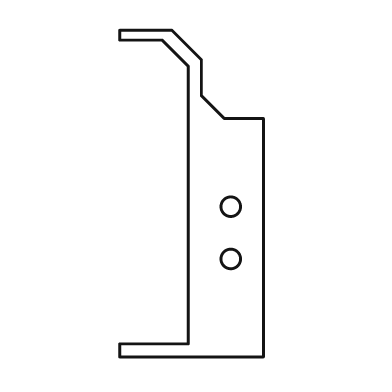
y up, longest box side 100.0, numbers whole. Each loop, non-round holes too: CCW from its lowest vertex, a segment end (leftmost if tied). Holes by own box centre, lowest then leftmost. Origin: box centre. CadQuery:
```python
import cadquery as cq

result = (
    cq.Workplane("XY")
    .moveTo(-22.0, -50.0)
    .lineTo(22.0, -50.0)
    .lineTo(22.0, 23.0)
    .lineTo(10.0, 23.0)
    .lineTo(3.0, 30.0)
    .lineTo(3.0, 41.0)
    .lineTo(-6.0, 50.0)
    .lineTo(-22.0, 50.0)
    .lineTo(-22.0, 47.0)
    .lineTo(-9.0, 47.0)
    .lineTo(-1.0, 39.0)
    .lineTo(-1.0, -46.0)
    .lineTo(-22.0, -46.0)
    .close()
    .moveTo(12.0, -20.0)
    .circle(3.0)
    .moveTo(12.0, -4.0)
    .circle(3.0)
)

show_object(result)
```